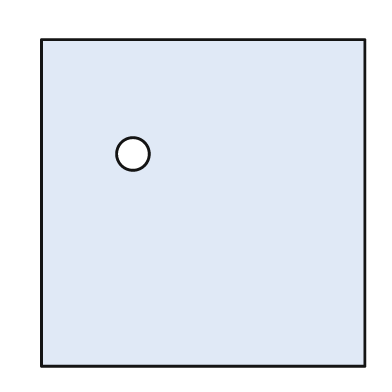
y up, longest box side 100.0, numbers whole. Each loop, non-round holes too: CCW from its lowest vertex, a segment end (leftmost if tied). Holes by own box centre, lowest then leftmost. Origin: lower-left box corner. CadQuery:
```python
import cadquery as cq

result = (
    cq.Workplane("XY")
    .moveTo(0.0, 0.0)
    .lineTo(99.0, 0.0)
    .lineTo(99.0, 100.0)
    .lineTo(0.0, 100.0)
    .close()
    .moveTo(28.0, 65.0)
    .circle(5.0)
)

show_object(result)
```